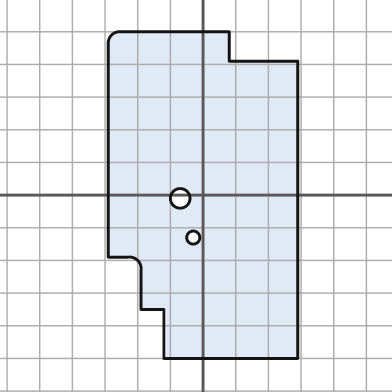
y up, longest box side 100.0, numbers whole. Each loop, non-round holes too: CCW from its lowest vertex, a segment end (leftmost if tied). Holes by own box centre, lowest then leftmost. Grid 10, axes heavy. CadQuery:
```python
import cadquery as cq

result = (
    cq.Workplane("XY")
    .moveTo(-12.0, -50.0)
    .lineTo(29.0, -50.0)
    .lineTo(29.0, 41.0)
    .lineTo(8.0, 41.0)
    .lineTo(8.0, 50.0)
    .lineTo(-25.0, 50.0)
    .threePointArc((-28.0, 49.0), (-29.0, 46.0))
    .lineTo(-29.0, -19.0)
    .lineTo(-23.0, -19.0)
    .threePointArc((-20.0, -20.0), (-19.0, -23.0))
    .lineTo(-19.0, -35.0)
    .lineTo(-12.0, -35.0)
    .close()
    .moveTo(-3.0, -13.0)
    .circle(2.0)
    .moveTo(-7.0, -1.0)
    .circle(3.0)
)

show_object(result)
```